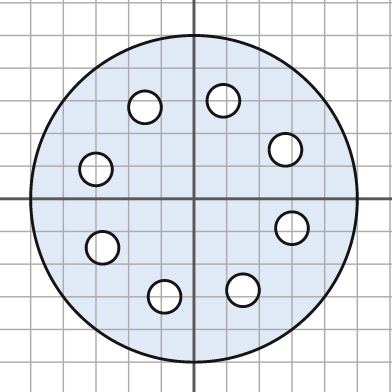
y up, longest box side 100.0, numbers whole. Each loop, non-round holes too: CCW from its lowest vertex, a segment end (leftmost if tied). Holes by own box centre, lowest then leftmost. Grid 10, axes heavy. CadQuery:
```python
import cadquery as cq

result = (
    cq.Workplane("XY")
    .moveTo(0.0, 0.0)
    .circle(50.0)
    .moveTo(-9.0, -30.0)
    .circle(5.0)
    .moveTo(15.0, -28.0)
    .circle(5.0)
    .moveTo(-28.0, -15.0)
    .circle(5.0)
    .moveTo(30.0, -9.0)
    .circle(5.0)
    .moveTo(-30.0, 9.0)
    .circle(5.0)
    .moveTo(28.0, 15.0)
    .circle(5.0)
    .moveTo(-15.0, 28.0)
    .circle(5.0)
    .moveTo(9.0, 30.0)
    .circle(5.0)
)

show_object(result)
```